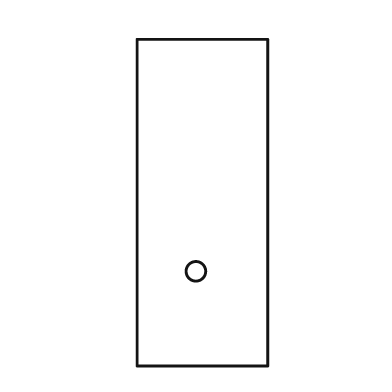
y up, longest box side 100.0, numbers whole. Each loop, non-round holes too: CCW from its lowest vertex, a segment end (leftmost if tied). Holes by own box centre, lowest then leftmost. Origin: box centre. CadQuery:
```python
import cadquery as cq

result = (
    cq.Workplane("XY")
    .moveTo(-20.0, -50.0)
    .lineTo(20.0, -50.0)
    .lineTo(20.0, 50.0)
    .lineTo(-20.0, 50.0)
    .close()
    .moveTo(-2.0, -21.0)
    .circle(3.0)
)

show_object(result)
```